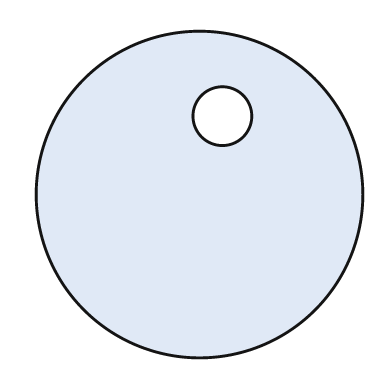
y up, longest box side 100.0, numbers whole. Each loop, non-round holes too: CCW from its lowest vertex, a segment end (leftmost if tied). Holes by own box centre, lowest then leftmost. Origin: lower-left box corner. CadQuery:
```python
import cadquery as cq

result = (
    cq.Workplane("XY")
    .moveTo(50.0, 50.0)
    .circle(50.0)
    .moveTo(57.0, 74.0)
    .circle(9.0)
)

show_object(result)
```